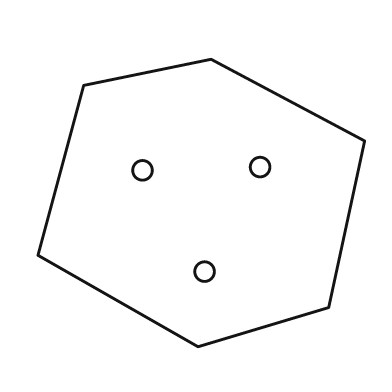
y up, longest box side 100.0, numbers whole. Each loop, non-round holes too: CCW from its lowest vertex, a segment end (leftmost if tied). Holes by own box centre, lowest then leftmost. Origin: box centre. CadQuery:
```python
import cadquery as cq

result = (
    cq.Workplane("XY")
    .moveTo(-1.0, -44.0)
    .lineTo(39.0, -32.0)
    .lineTo(50.0, 19.0)
    .lineTo(3.0, 44.0)
    .lineTo(-36.0, 36.0)
    .lineTo(-50.0, -16.0)
    .close()
    .moveTo(1.0, -21.0)
    .circle(3.0)
    .moveTo(-18.0, 10.0)
    .circle(3.0)
    .moveTo(18.0, 11.0)
    .circle(3.0)
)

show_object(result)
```